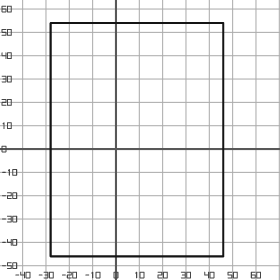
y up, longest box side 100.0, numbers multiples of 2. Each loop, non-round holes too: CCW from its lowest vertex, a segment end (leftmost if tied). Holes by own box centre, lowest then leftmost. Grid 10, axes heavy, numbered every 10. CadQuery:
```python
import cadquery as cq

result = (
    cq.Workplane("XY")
    .moveTo(-28.0, -46.0)
    .lineTo(46.0, -46.0)
    .lineTo(46.0, 54.0)
    .lineTo(-28.0, 54.0)
    .close()
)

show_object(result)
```